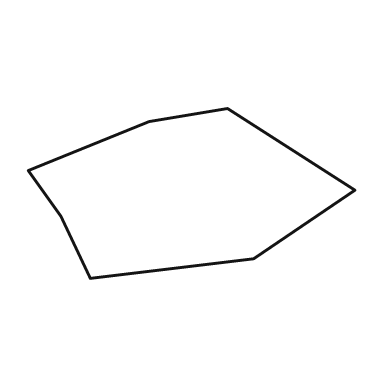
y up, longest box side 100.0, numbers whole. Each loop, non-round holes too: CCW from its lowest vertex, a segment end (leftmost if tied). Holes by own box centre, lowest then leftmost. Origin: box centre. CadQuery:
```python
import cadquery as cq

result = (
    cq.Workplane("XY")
    .moveTo(-31.0, -26.0)
    .lineTo(19.0, -20.0)
    .lineTo(50.0, 1.0)
    .lineTo(11.0, 26.0)
    .lineTo(-13.0, 22.0)
    .lineTo(-50.0, 7.0)
    .lineTo(-40.0, -7.0)
    .close()
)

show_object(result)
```